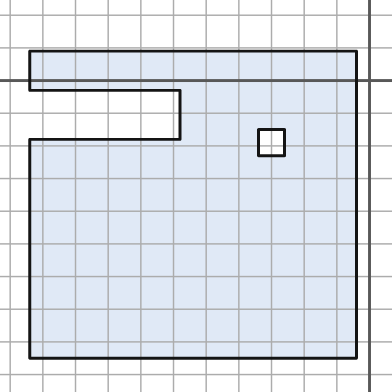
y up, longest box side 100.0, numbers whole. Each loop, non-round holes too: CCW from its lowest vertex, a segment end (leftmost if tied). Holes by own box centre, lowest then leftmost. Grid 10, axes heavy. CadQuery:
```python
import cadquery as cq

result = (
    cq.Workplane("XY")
    .moveTo(-104.0, -85.0)
    .lineTo(-4.0, -85.0)
    .lineTo(-4.0, 9.0)
    .lineTo(-104.0, 9.0)
    .lineTo(-104.0, -3.0)
    .lineTo(-58.0, -3.0)
    .lineTo(-58.0, -18.0)
    .lineTo(-104.0, -18.0)
    .close()
    .moveTo(-34.0, -23.0)
    .lineTo(-26.0, -23.0)
    .lineTo(-26.0, -15.0)
    .lineTo(-34.0, -15.0)
    .close()
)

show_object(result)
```